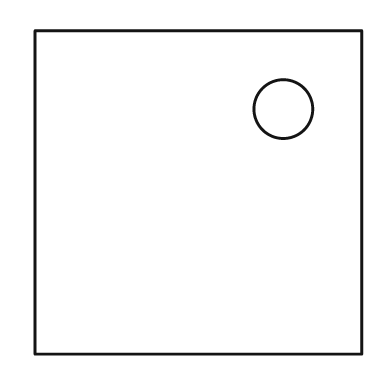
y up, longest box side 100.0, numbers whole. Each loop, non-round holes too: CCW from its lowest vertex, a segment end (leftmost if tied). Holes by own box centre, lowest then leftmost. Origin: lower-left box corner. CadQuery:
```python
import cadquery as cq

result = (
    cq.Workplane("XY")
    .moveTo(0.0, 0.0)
    .lineTo(100.0, 0.0)
    .lineTo(100.0, 99.0)
    .lineTo(0.0, 99.0)
    .close()
    .moveTo(76.0, 75.0)
    .circle(9.0)
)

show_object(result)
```